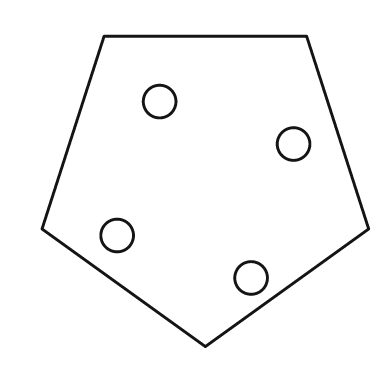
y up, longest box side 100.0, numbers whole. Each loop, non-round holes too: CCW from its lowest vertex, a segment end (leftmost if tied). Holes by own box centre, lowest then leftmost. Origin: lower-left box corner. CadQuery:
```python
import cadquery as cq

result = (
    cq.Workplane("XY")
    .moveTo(50.0, 0.0)
    .lineTo(100.0, 36.0)
    .lineTo(81.0, 95.0)
    .lineTo(19.0, 95.0)
    .lineTo(0.0, 36.0)
    .close()
    .moveTo(64.0, 21.0)
    .circle(5.0)
    .moveTo(23.0, 34.0)
    .circle(5.0)
    .moveTo(77.0, 62.0)
    .circle(5.0)
    .moveTo(36.0, 75.0)
    .circle(5.0)
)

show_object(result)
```